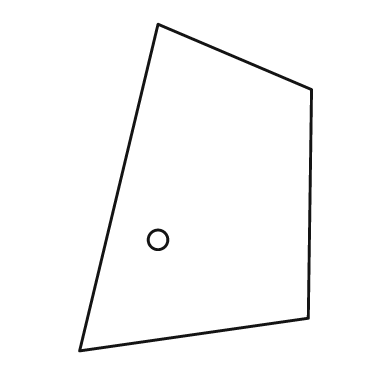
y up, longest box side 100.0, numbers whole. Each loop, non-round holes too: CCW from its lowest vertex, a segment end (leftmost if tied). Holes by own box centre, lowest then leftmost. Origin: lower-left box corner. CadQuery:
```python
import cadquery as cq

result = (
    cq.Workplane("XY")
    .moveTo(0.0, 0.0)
    .lineTo(70.0, 10.0)
    .lineTo(71.0, 80.0)
    .lineTo(24.0, 100.0)
    .close()
    .moveTo(24.0, 34.0)
    .circle(3.0)
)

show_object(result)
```